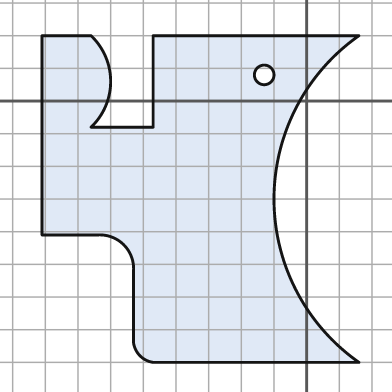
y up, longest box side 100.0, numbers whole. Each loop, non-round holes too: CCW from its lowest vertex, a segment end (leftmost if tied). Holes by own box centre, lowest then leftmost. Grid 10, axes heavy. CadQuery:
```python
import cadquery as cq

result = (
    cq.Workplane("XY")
    .moveTo(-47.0, -80.0)
    .lineTo(16.0, -80.0)
    .threePointArc((-10.0, -30.0), (16.0, 20.0))
    .lineTo(-47.0, 20.0)
    .lineTo(-47.0, -8.0)
    .lineTo(-66.0, -8.0)
    .threePointArc((-60.0, 6.0), (-66.0, 20.0))
    .lineTo(-81.0, 20.0)
    .lineTo(-81.0, -41.0)
    .lineTo(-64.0, -41.0)
    .threePointArc((-56.0, -44.0), (-53.0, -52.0))
    .lineTo(-53.0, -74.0)
    .threePointArc((-51.0, -78.0), (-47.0, -80.0))
    .close()
    .moveTo(-13.0, 8.0)
    .circle(3.0)
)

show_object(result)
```